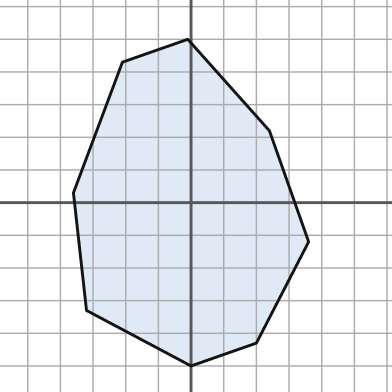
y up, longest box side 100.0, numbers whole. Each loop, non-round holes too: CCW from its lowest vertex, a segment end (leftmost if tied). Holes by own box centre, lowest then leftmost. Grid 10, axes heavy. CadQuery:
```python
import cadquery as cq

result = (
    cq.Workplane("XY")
    .moveTo(0.0, -50.0)
    .lineTo(20.0, -43.0)
    .lineTo(36.0, -12.0)
    .lineTo(24.0, 22.0)
    .lineTo(-1.0, 50.0)
    .lineTo(-21.0, 43.0)
    .lineTo(-36.0, 3.0)
    .lineTo(-32.0, -33.0)
    .close()
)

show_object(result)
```